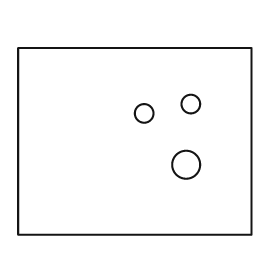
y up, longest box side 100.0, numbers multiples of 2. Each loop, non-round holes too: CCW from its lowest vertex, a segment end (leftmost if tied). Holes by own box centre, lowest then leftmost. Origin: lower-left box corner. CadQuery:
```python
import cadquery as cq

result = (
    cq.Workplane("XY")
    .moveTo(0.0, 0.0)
    .lineTo(100.0, 0.0)
    .lineTo(100.0, 80.0)
    .lineTo(0.0, 80.0)
    .close()
    .moveTo(72.0, 30.0)
    .circle(6.0)
    .moveTo(54.0, 52.0)
    .circle(4.0)
    .moveTo(74.0, 56.0)
    .circle(4.0)
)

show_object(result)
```